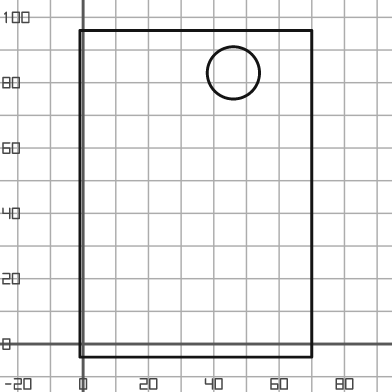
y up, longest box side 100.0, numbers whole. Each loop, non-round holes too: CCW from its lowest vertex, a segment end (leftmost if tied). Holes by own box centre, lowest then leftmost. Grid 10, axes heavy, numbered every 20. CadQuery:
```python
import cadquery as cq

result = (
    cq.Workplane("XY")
    .moveTo(-1.0, -4.0)
    .lineTo(70.0, -4.0)
    .lineTo(70.0, 96.0)
    .lineTo(-1.0, 96.0)
    .close()
    .moveTo(46.0, 83.0)
    .circle(8.0)
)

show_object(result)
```